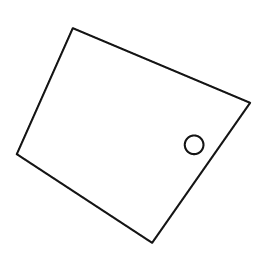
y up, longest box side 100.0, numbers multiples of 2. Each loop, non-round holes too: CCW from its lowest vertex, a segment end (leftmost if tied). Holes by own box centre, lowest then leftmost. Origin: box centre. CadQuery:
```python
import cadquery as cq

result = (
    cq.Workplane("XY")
    .moveTo(8.0, -46.0)
    .lineTo(50.0, 14.0)
    .lineTo(-26.0, 46.0)
    .lineTo(-50.0, -8.0)
    .close()
    .moveTo(26.0, -4.0)
    .circle(4.0)
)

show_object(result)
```